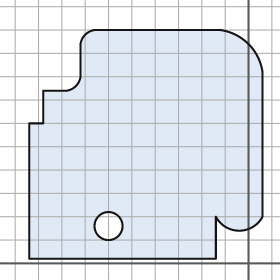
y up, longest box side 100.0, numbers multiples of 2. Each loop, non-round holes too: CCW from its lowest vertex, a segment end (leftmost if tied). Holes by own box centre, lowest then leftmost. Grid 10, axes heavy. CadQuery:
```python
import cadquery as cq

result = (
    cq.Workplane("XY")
    .moveTo(-94.0, 2.0)
    .lineTo(-14.0, 2.0)
    .lineTo(-14.0, 20.0)
    .threePointArc((-4.0, 14.0), (6.0, 20.0))
    .lineTo(6.0, 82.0)
    .threePointArc((0.0, 94.0), (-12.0, 100.0))
    .lineTo(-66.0, 100.0)
    .threePointArc((-70.0, 98.0), (-72.0, 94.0))
    .lineTo(-72.0, 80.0)
    .threePointArc((-74.0, 76.0), (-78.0, 74.0))
    .lineTo(-88.0, 74.0)
    .lineTo(-88.0, 60.0)
    .lineTo(-94.0, 60.0)
    .close()
    .moveTo(-60.0, 16.0)
    .circle(6.0)
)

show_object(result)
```